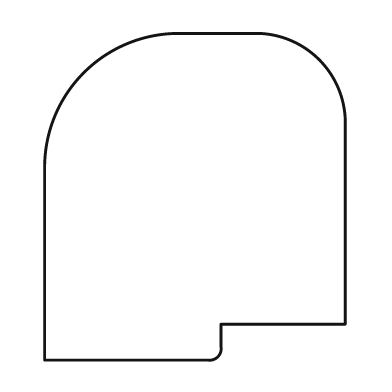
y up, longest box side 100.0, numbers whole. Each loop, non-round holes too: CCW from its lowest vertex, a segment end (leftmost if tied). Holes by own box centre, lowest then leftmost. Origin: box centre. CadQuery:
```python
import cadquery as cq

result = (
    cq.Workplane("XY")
    .moveTo(-46.0, -50.0)
    .lineTo(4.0, -50.0)
    .threePointArc((7.0, -49.0), (8.0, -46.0))
    .lineTo(8.0, -39.0)
    .lineTo(46.0, -39.0)
    .lineTo(46.0, 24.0)
    .threePointArc((38.0, 42.0), (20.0, 50.0))
    .lineTo(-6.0, 50.0)
    .threePointArc((-34.0, 38.0), (-46.0, 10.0))
    .close()
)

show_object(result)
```